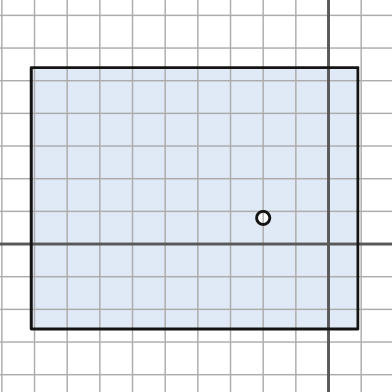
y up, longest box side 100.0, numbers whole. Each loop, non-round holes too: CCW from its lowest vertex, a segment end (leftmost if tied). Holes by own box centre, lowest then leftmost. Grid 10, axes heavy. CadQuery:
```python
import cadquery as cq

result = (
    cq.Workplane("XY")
    .moveTo(-91.0, -26.0)
    .lineTo(9.0, -26.0)
    .lineTo(9.0, 54.0)
    .lineTo(-91.0, 54.0)
    .close()
    .moveTo(-20.0, 8.0)
    .circle(2.0)
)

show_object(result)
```